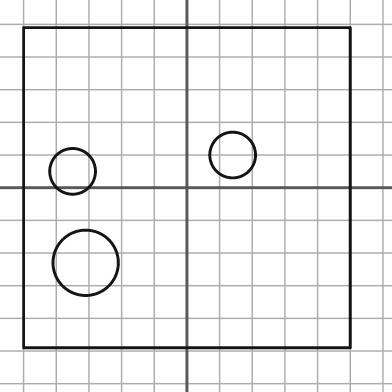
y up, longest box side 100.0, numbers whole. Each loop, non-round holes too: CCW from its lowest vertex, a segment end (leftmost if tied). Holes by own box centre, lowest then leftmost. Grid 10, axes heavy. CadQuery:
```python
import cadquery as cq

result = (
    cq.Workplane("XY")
    .moveTo(-50.0, -49.0)
    .lineTo(50.0, -49.0)
    .lineTo(50.0, 49.0)
    .lineTo(-50.0, 49.0)
    .close()
    .moveTo(-31.0, -23.0)
    .circle(10.0)
    .moveTo(-35.0, 5.0)
    .circle(7.0)
    .moveTo(14.0, 10.0)
    .circle(7.0)
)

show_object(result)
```